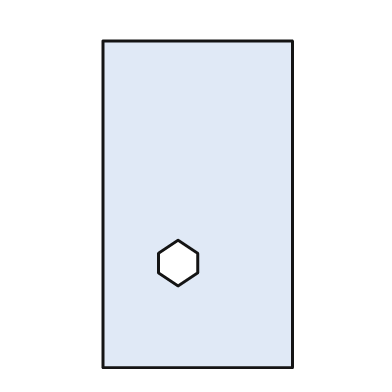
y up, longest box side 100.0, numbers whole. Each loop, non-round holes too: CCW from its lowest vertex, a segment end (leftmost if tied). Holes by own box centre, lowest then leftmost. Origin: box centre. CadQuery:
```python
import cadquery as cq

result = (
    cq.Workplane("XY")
    .moveTo(-29.0, -50.0)
    .lineTo(29.0, -50.0)
    .lineTo(29.0, 50.0)
    .lineTo(-29.0, 50.0)
    .close()
    .moveTo(-6.0, -25.0)
    .lineTo(0.0, -21.0)
    .lineTo(0.0, -15.0)
    .lineTo(-6.0, -11.0)
    .lineTo(-12.0, -15.0)
    .lineTo(-12.0, -21.0)
    .close()
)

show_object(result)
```